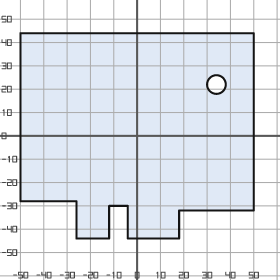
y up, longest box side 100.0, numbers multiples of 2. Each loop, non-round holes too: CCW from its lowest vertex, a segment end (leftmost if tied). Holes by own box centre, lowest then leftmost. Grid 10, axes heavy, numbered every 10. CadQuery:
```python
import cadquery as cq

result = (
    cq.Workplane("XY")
    .moveTo(-26.0, -44.0)
    .lineTo(-12.0, -44.0)
    .lineTo(-12.0, -30.0)
    .lineTo(-4.0, -30.0)
    .lineTo(-4.0, -44.0)
    .lineTo(18.0, -44.0)
    .lineTo(18.0, -32.0)
    .lineTo(50.0, -32.0)
    .lineTo(50.0, 44.0)
    .lineTo(-50.0, 44.0)
    .lineTo(-50.0, -28.0)
    .lineTo(-26.0, -28.0)
    .close()
    .moveTo(34.0, 22.0)
    .circle(4.0)
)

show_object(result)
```